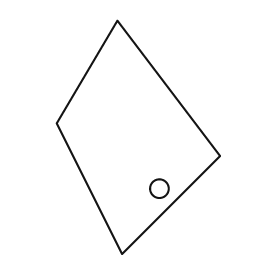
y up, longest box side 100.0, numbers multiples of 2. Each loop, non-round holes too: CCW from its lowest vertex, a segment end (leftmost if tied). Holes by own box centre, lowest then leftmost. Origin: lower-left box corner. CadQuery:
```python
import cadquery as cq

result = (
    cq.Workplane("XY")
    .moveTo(28.0, 0.0)
    .lineTo(70.0, 42.0)
    .lineTo(26.0, 100.0)
    .lineTo(0.0, 56.0)
    .close()
    .moveTo(44.0, 28.0)
    .circle(4.0)
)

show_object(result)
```